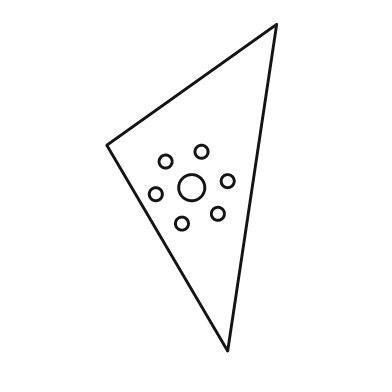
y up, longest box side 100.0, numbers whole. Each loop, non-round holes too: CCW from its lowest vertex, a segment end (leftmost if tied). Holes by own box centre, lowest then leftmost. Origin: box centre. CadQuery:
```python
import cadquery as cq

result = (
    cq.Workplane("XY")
    .moveTo(11.0, -50.0)
    .lineTo(26.0, 50.0)
    .lineTo(-26.0, 13.0)
    .close()
    .moveTo(-3.0, -11.0)
    .circle(2.0)
    .moveTo(8.0, -8.0)
    .circle(2.0)
    .moveTo(-11.0, -2.0)
    .circle(2.0)
    .moveTo(0.0, 0.0)
    .circle(4.0)
    .moveTo(11.0, 2.0)
    .circle(2.0)
    .moveTo(-8.0, 8.0)
    .circle(2.0)
    .moveTo(3.0, 11.0)
    .circle(2.0)
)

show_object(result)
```